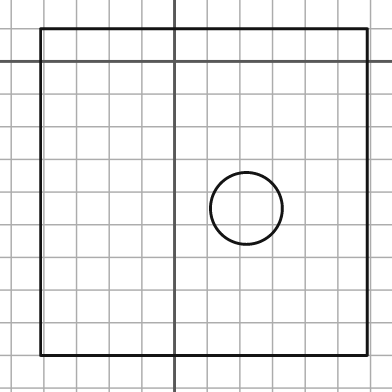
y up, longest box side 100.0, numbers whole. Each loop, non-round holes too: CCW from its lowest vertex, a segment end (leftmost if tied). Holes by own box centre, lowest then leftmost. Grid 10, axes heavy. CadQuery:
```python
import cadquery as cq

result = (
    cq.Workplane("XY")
    .moveTo(-41.0, -90.0)
    .lineTo(59.0, -90.0)
    .lineTo(59.0, 10.0)
    .lineTo(-41.0, 10.0)
    .close()
    .moveTo(22.0, -45.0)
    .circle(11.0)
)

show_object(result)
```